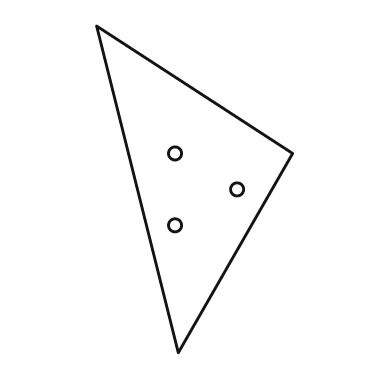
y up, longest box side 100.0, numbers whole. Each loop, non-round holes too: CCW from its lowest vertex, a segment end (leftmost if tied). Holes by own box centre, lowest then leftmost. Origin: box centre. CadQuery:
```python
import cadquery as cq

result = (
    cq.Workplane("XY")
    .moveTo(-5.0, -50.0)
    .lineTo(30.0, 11.0)
    .lineTo(-30.0, 50.0)
    .close()
    .moveTo(-6.0, -11.0)
    .circle(2.0)
    .moveTo(13.0, 0.0)
    .circle(2.0)
    .moveTo(-6.0, 11.0)
    .circle(2.0)
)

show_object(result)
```